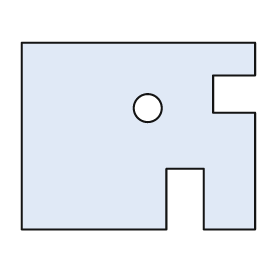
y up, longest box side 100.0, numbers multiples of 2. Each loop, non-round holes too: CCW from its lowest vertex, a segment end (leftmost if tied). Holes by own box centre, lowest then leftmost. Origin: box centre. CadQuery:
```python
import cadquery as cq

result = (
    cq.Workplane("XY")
    .moveTo(-50.0, -40.0)
    .lineTo(12.0, -40.0)
    .lineTo(12.0, -14.0)
    .lineTo(28.0, -14.0)
    .lineTo(28.0, -40.0)
    .lineTo(50.0, -40.0)
    .lineTo(50.0, 10.0)
    .lineTo(32.0, 10.0)
    .lineTo(32.0, 26.0)
    .lineTo(50.0, 26.0)
    .lineTo(50.0, 40.0)
    .lineTo(-50.0, 40.0)
    .close()
    .moveTo(4.0, 12.0)
    .circle(6.0)
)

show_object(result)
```